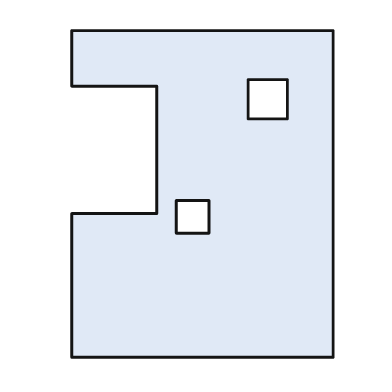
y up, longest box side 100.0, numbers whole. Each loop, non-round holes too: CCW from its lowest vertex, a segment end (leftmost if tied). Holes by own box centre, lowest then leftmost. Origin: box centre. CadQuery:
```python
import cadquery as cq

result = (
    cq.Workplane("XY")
    .moveTo(-40.0, -50.0)
    .lineTo(40.0, -50.0)
    .lineTo(40.0, 50.0)
    .lineTo(-40.0, 50.0)
    .lineTo(-40.0, 33.0)
    .lineTo(-14.0, 33.0)
    .lineTo(-14.0, -6.0)
    .lineTo(-40.0, -6.0)
    .close()
    .moveTo(-8.0, -12.0)
    .lineTo(2.0, -12.0)
    .lineTo(2.0, -2.0)
    .lineTo(-8.0, -2.0)
    .close()
    .moveTo(14.0, 23.0)
    .lineTo(26.0, 23.0)
    .lineTo(26.0, 35.0)
    .lineTo(14.0, 35.0)
    .close()
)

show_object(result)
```